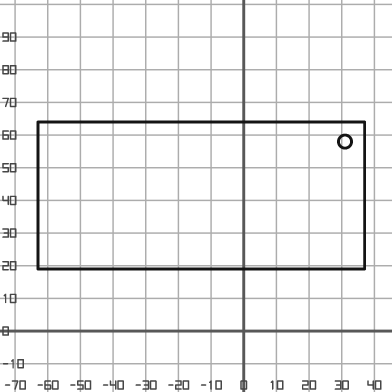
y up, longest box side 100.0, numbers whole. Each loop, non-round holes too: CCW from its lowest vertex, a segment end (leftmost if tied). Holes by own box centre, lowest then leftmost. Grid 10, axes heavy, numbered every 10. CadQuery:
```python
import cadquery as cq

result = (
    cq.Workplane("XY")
    .moveTo(-63.0, 19.0)
    .lineTo(37.0, 19.0)
    .lineTo(37.0, 64.0)
    .lineTo(-63.0, 64.0)
    .close()
    .moveTo(31.0, 58.0)
    .circle(2.0)
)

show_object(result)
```